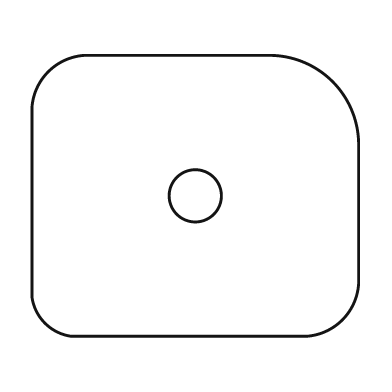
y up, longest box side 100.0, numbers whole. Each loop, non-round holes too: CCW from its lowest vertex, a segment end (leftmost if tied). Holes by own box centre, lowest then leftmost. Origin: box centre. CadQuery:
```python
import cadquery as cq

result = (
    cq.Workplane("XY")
    .moveTo(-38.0, -43.0)
    .lineTo(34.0, -43.0)
    .threePointArc((45.0, -38.0), (50.0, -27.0))
    .lineTo(50.0, 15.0)
    .threePointArc((42.0, 35.0), (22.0, 43.0))
    .lineTo(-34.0, 43.0)
    .threePointArc((-45.0, 38.0), (-50.0, 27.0))
    .lineTo(-50.0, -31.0)
    .threePointArc((-46.0, -39.0), (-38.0, -43.0))
    .close()
    .moveTo(0.0, 0.0)
    .circle(8.0)
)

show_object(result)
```